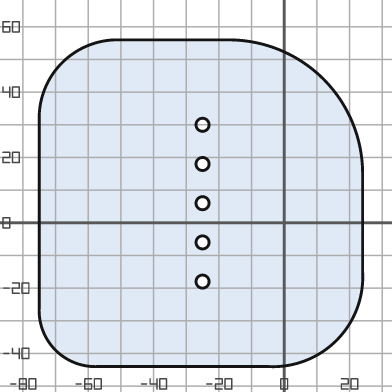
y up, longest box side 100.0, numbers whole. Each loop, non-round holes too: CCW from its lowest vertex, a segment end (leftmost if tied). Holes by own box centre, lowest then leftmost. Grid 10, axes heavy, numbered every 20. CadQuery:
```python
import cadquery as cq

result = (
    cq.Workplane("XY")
    .moveTo(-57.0, -44.0)
    .lineTo(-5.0, -44.0)
    .threePointArc((16.0, -36.0), (24.0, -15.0))
    .lineTo(24.0, 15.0)
    .threePointArc((12.0, 44.0), (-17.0, 56.0))
    .lineTo(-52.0, 56.0)
    .threePointArc((-68.0, 49.0), (-75.0, 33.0))
    .lineTo(-75.0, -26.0)
    .threePointArc((-70.0, -39.0), (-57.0, -44.0))
    .close()
    .moveTo(-25.0, -18.0)
    .circle(2.0)
    .moveTo(-25.0, -6.0)
    .circle(2.0)
    .moveTo(-25.0, 6.0)
    .circle(2.0)
    .moveTo(-25.0, 18.0)
    .circle(2.0)
    .moveTo(-25.0, 30.0)
    .circle(2.0)
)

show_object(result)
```